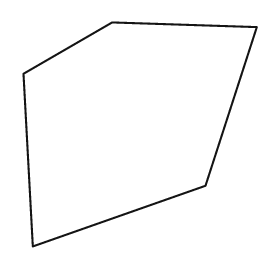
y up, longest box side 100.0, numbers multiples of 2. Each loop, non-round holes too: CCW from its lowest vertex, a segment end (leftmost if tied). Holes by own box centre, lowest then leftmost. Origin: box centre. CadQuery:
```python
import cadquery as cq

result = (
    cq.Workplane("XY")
    .moveTo(-46.0, -48.0)
    .lineTo(28.0, -22.0)
    .lineTo(50.0, 46.0)
    .lineTo(-12.0, 48.0)
    .lineTo(-50.0, 26.0)
    .close()
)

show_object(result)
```